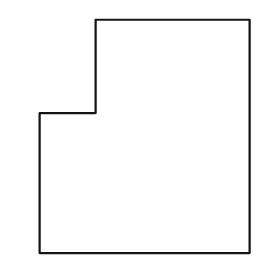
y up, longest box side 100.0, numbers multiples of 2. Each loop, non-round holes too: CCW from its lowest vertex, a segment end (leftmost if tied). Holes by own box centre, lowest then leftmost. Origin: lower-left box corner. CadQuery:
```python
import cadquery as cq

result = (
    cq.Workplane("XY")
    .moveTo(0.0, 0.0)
    .lineTo(90.0, 0.0)
    .lineTo(90.0, 100.0)
    .lineTo(24.0, 100.0)
    .lineTo(24.0, 60.0)
    .lineTo(0.0, 60.0)
    .close()
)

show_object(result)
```